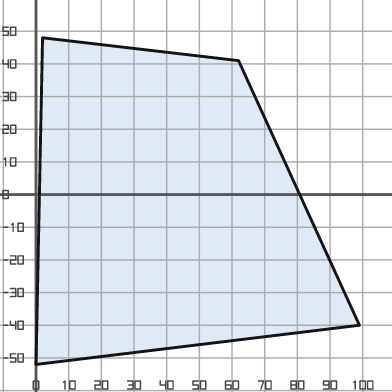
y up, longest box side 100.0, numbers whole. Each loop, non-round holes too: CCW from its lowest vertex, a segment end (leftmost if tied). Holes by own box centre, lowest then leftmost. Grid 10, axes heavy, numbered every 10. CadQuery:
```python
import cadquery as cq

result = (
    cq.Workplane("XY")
    .moveTo(0.0, -52.0)
    .lineTo(99.0, -40.0)
    .lineTo(62.0, 41.0)
    .lineTo(2.0, 48.0)
    .close()
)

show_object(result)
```